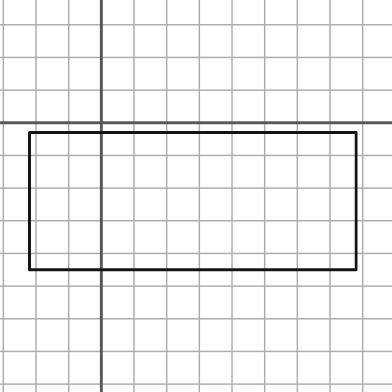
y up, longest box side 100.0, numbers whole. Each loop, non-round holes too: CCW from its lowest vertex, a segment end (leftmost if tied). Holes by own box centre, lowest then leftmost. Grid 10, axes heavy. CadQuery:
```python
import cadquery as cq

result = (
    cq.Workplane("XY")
    .moveTo(-22.0, -45.0)
    .lineTo(78.0, -45.0)
    .lineTo(78.0, -3.0)
    .lineTo(-22.0, -3.0)
    .close()
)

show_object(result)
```